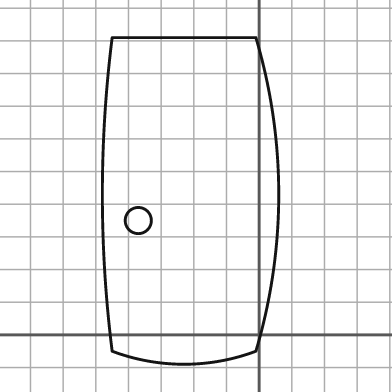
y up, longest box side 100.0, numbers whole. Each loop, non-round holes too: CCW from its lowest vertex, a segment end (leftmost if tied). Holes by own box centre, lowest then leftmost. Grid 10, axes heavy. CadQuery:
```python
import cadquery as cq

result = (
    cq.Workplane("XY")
    .moveTo(-45.0, -5.0)
    .threePointArc((-23.0, -9.0), (-1.0, -5.0))
    .threePointArc((6.0, 43.0), (-1.0, 91.0))
    .lineTo(-45.0, 91.0)
    .threePointArc((-48.0, 43.0), (-45.0, -5.0))
    .close()
    .moveTo(-37.0, 35.0)
    .circle(4.0)
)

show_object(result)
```